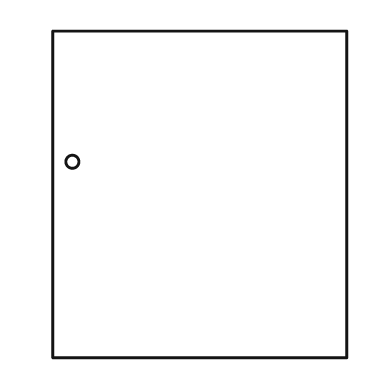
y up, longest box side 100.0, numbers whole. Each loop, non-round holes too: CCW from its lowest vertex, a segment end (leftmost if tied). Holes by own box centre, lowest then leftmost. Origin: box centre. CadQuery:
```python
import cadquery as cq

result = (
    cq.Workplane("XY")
    .moveTo(-45.0, -50.0)
    .lineTo(45.0, -50.0)
    .lineTo(45.0, 50.0)
    .lineTo(-45.0, 50.0)
    .close()
    .moveTo(-39.0, 10.0)
    .circle(2.0)
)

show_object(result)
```